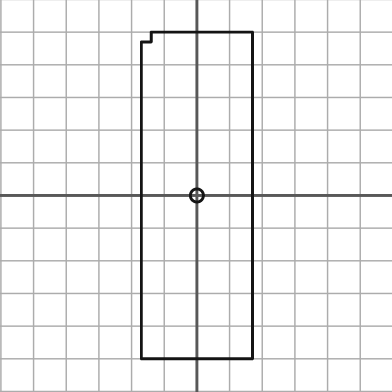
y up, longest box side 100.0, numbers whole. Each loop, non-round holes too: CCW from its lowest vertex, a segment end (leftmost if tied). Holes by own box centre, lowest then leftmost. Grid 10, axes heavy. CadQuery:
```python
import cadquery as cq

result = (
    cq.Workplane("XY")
    .moveTo(-17.0, -50.0)
    .lineTo(17.0, -50.0)
    .lineTo(17.0, 50.0)
    .lineTo(-14.0, 50.0)
    .lineTo(-14.0, 47.0)
    .lineTo(-17.0, 47.0)
    .close()
    .moveTo(0.0, 0.0)
    .circle(2.0)
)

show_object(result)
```